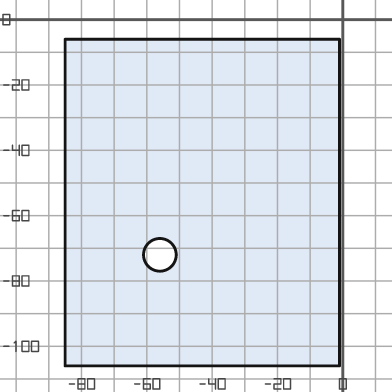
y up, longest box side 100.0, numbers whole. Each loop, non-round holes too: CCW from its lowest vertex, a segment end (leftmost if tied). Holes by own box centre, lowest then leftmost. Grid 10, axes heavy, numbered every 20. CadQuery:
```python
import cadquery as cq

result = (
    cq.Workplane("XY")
    .moveTo(-85.0, -106.0)
    .lineTo(-1.0, -106.0)
    .lineTo(-1.0, -6.0)
    .lineTo(-85.0, -6.0)
    .close()
    .moveTo(-56.0, -72.0)
    .circle(5.0)
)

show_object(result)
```